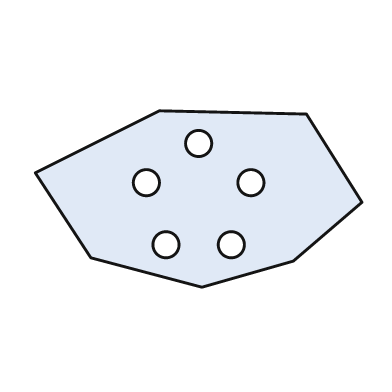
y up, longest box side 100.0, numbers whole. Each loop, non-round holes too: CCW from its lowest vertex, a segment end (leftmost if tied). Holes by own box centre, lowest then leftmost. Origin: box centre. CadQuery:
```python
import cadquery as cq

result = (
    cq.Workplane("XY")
    .moveTo(1.0, -27.0)
    .lineTo(29.0, -19.0)
    .lineTo(50.0, -1.0)
    .lineTo(33.0, 26.0)
    .lineTo(-12.0, 27.0)
    .lineTo(-50.0, 8.0)
    .lineTo(-33.0, -18.0)
    .close()
    .moveTo(-10.0, -14.0)
    .circle(4.0)
    .moveTo(10.0, -14.0)
    .circle(4.0)
    .moveTo(-16.0, 5.0)
    .circle(4.0)
    .moveTo(16.0, 5.0)
    .circle(4.0)
    .moveTo(0.0, 17.0)
    .circle(4.0)
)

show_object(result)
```